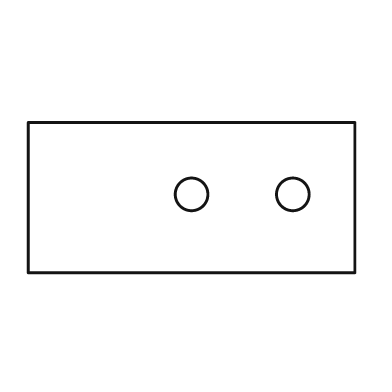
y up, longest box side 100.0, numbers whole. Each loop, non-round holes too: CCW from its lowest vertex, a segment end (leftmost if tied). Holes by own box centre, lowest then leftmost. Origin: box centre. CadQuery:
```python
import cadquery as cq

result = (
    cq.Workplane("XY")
    .moveTo(-50.0, -23.0)
    .lineTo(50.0, -23.0)
    .lineTo(50.0, 23.0)
    .lineTo(-50.0, 23.0)
    .close()
    .moveTo(0.0, 1.0)
    .circle(5.0)
    .moveTo(31.0, 1.0)
    .circle(5.0)
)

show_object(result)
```